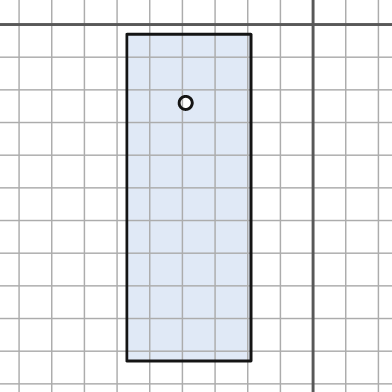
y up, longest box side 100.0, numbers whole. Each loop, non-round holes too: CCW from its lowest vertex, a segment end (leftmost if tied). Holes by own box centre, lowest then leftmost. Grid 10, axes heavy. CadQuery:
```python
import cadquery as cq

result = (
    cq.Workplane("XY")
    .moveTo(-57.0, -103.0)
    .lineTo(-19.0, -103.0)
    .lineTo(-19.0, -3.0)
    .lineTo(-57.0, -3.0)
    .close()
    .moveTo(-39.0, -24.0)
    .circle(2.0)
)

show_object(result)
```